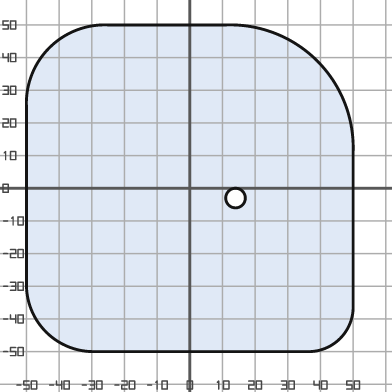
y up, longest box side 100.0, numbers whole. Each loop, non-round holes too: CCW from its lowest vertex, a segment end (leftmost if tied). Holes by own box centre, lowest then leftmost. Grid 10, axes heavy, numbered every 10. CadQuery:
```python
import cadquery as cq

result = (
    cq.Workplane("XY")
    .moveTo(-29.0, -50.0)
    .lineTo(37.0, -50.0)
    .threePointArc((46.0, -46.0), (50.0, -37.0))
    .lineTo(50.0, 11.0)
    .threePointArc((39.0, 39.0), (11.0, 50.0))
    .lineTo(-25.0, 50.0)
    .threePointArc((-43.0, 43.0), (-50.0, 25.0))
    .lineTo(-50.0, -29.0)
    .threePointArc((-44.0, -44.0), (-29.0, -50.0))
    .close()
    .moveTo(14.0, -3.0)
    .circle(3.0)
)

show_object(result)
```